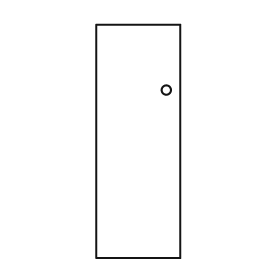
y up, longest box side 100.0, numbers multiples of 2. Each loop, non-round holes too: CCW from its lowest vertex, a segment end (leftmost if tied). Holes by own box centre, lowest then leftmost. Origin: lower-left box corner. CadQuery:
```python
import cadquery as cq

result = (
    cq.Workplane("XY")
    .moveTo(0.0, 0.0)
    .lineTo(36.0, 0.0)
    .lineTo(36.0, 100.0)
    .lineTo(0.0, 100.0)
    .close()
    .moveTo(30.0, 72.0)
    .circle(2.0)
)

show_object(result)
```